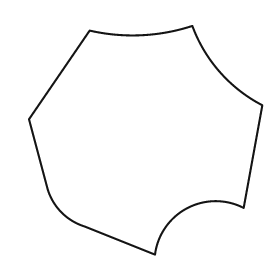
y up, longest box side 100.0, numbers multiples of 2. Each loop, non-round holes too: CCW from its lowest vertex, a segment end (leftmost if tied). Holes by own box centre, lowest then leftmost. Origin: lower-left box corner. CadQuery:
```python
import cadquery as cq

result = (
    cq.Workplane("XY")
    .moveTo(54.0, 0.0)
    .threePointArc((68.0, 20.0), (92.0, 20.0))
    .lineTo(100.0, 64.0)
    .threePointArc((82.0, 78.0), (70.0, 98.0))
    .threePointArc((48.0, 94.0), (26.0, 96.0))
    .lineTo(0.0, 58.0)
    .lineTo(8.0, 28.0)
    .threePointArc((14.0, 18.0), (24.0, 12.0))
    .close()
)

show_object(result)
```